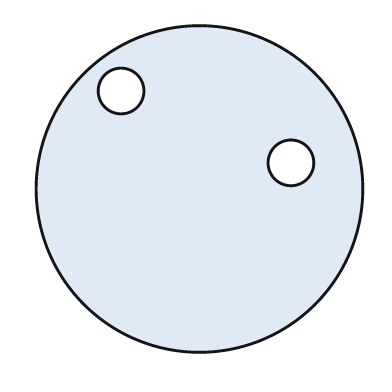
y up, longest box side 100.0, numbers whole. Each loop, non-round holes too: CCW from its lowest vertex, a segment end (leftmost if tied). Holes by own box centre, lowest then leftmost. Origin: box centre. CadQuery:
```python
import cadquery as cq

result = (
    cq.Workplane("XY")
    .moveTo(0.0, 0.0)
    .circle(50.0)
    .moveTo(28.0, 8.0)
    .circle(7.0)
    .moveTo(-24.0, 30.0)
    .circle(7.0)
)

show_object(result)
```